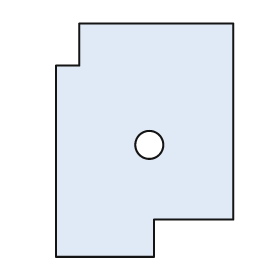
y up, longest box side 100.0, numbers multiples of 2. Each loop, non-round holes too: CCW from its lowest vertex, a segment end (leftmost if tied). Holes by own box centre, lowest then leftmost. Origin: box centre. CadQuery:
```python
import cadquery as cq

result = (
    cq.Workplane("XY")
    .moveTo(-38.0, -50.0)
    .lineTo(4.0, -50.0)
    .lineTo(4.0, -34.0)
    .lineTo(38.0, -34.0)
    .lineTo(38.0, 50.0)
    .lineTo(-28.0, 50.0)
    .lineTo(-28.0, 32.0)
    .lineTo(-38.0, 32.0)
    .close()
    .moveTo(2.0, -2.0)
    .circle(6.0)
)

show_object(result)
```